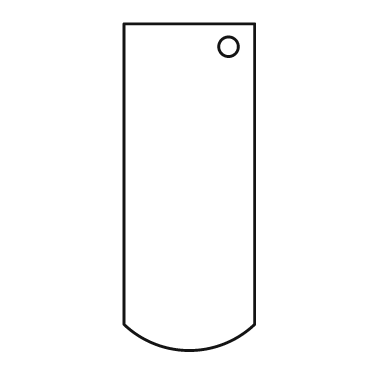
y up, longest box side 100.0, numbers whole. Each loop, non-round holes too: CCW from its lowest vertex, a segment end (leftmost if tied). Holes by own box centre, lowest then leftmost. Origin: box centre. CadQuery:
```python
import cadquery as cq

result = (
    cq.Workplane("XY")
    .moveTo(-20.0, -42.0)
    .threePointArc((0.0, -50.0), (20.0, -42.0))
    .lineTo(20.0, 50.0)
    .lineTo(-20.0, 50.0)
    .close()
    .moveTo(12.0, 43.0)
    .circle(3.0)
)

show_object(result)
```